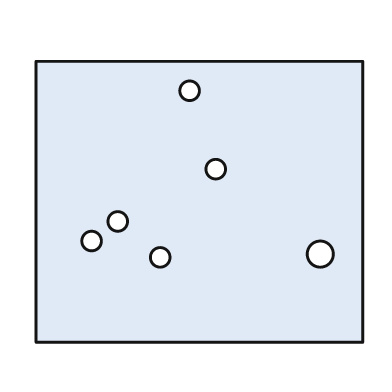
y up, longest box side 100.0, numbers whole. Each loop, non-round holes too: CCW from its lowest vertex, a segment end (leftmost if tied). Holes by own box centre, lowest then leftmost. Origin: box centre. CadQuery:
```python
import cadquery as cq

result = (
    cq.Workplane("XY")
    .moveTo(-50.0, -43.0)
    .lineTo(50.0, -43.0)
    .lineTo(50.0, 43.0)
    .lineTo(-50.0, 43.0)
    .close()
    .moveTo(-12.0, -17.0)
    .circle(3.0)
    .moveTo(37.0, -16.0)
    .circle(4.0)
    .moveTo(-33.0, -12.0)
    .circle(3.0)
    .moveTo(-25.0, -6.0)
    .circle(3.0)
    .moveTo(5.0, 10.0)
    .circle(3.0)
    .moveTo(-3.0, 34.0)
    .circle(3.0)
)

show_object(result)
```